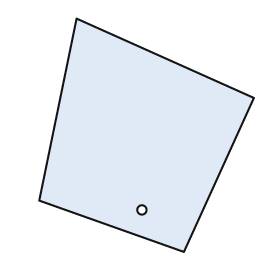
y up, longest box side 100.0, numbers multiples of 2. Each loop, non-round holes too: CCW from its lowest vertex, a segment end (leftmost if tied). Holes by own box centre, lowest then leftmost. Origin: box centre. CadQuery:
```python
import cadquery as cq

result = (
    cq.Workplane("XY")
    .moveTo(16.0, -50.0)
    .lineTo(46.0, 16.0)
    .lineTo(-30.0, 50.0)
    .lineTo(-46.0, -28.0)
    .close()
    .moveTo(-2.0, -32.0)
    .circle(2.0)
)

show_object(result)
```